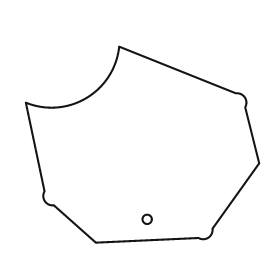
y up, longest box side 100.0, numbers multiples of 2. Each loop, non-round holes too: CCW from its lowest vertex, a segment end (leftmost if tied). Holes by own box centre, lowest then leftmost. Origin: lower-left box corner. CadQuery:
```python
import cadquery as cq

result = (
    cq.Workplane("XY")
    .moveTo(30.0, 0.0)
    .lineTo(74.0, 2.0)
    .threePointArc((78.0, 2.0), (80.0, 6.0))
    .lineTo(100.0, 34.0)
    .lineTo(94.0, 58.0)
    .threePointArc((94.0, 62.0), (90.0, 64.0))
    .lineTo(40.0, 84.0)
    .threePointArc((26.0, 62.0), (0.0, 60.0))
    .lineTo(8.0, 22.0)
    .threePointArc((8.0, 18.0), (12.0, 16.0))
    .close()
    .moveTo(52.0, 10.0)
    .circle(2.0)
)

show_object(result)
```